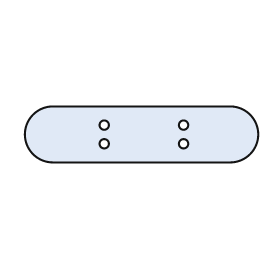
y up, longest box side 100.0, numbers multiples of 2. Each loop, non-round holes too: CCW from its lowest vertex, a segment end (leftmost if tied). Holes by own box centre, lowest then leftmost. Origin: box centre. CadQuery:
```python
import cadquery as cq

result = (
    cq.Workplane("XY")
    .moveTo(-38.0, -12.0)
    .lineTo(38.0, -12.0)
    .threePointArc((50.0, 0.0), (38.0, 12.0))
    .lineTo(-38.0, 12.0)
    .threePointArc((-50.0, 0.0), (-38.0, -12.0))
    .close()
    .moveTo(-16.0, -4.0)
    .circle(2.0)
    .moveTo(18.0, -4.0)
    .circle(2.0)
    .moveTo(-16.0, 4.0)
    .circle(2.0)
    .moveTo(18.0, 4.0)
    .circle(2.0)
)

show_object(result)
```